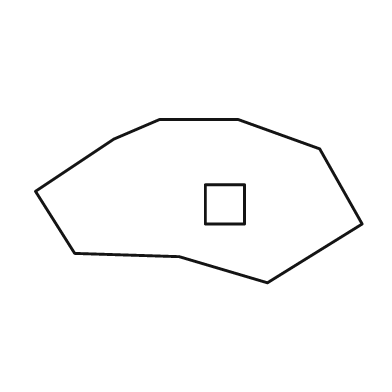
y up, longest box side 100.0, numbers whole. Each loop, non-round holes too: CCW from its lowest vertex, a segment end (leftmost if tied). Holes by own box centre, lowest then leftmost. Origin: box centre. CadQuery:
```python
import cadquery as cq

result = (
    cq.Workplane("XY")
    .moveTo(21.0, -25.0)
    .lineTo(50.0, -7.0)
    .lineTo(37.0, 16.0)
    .lineTo(12.0, 25.0)
    .lineTo(-12.0, 25.0)
    .lineTo(-26.0, 19.0)
    .lineTo(-50.0, 3.0)
    .lineTo(-38.0, -16.0)
    .lineTo(-6.0, -17.0)
    .close()
    .moveTo(2.0, -7.0)
    .lineTo(14.0, -7.0)
    .lineTo(14.0, 5.0)
    .lineTo(2.0, 5.0)
    .close()
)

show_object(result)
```